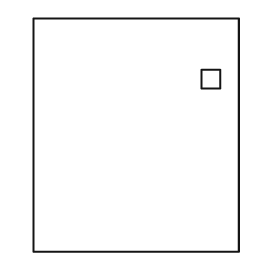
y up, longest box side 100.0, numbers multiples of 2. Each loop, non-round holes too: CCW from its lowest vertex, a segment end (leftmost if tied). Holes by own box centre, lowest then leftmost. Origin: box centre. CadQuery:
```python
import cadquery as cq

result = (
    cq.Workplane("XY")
    .moveTo(-44.0, -50.0)
    .lineTo(44.0, -50.0)
    .lineTo(44.0, 50.0)
    .lineTo(-44.0, 50.0)
    .close()
    .moveTo(28.0, 20.0)
    .lineTo(36.0, 20.0)
    .lineTo(36.0, 28.0)
    .lineTo(28.0, 28.0)
    .close()
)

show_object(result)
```